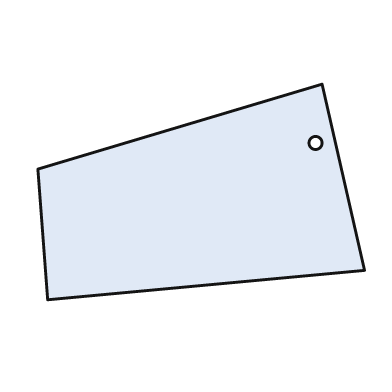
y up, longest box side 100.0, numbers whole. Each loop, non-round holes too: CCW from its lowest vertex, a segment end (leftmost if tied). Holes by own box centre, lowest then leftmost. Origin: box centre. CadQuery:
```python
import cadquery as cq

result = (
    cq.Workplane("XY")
    .moveTo(-47.0, -33.0)
    .lineTo(50.0, -24.0)
    .lineTo(37.0, 33.0)
    .lineTo(-50.0, 7.0)
    .close()
    .moveTo(35.0, 15.0)
    .circle(2.0)
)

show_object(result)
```